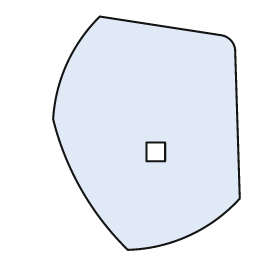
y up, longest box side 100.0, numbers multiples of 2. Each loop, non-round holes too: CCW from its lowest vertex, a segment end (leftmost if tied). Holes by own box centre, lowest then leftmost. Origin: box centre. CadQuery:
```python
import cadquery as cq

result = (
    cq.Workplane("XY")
    .moveTo(-8.0, -50.0)
    .threePointArc((18.0, -44.0), (40.0, -28.0))
    .lineTo(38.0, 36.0)
    .threePointArc((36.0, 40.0), (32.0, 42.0))
    .lineTo(-20.0, 50.0)
    .threePointArc((-34.0, 30.0), (-40.0, 6.0))
    .threePointArc((-28.0, -24.0), (-8.0, -50.0))
    .close()
    .moveTo(0.0, -12.0)
    .lineTo(8.0, -12.0)
    .lineTo(8.0, -4.0)
    .lineTo(0.0, -4.0)
    .close()
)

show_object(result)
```